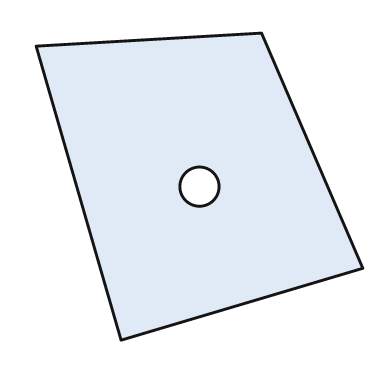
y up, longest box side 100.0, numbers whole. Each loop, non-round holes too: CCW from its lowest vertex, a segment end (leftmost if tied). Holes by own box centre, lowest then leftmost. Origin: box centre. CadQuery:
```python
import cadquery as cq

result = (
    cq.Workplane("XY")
    .moveTo(-24.0, -47.0)
    .lineTo(50.0, -25.0)
    .lineTo(19.0, 47.0)
    .lineTo(-50.0, 43.0)
    .close()
    .moveTo(0.0, 0.0)
    .circle(6.0)
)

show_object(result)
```